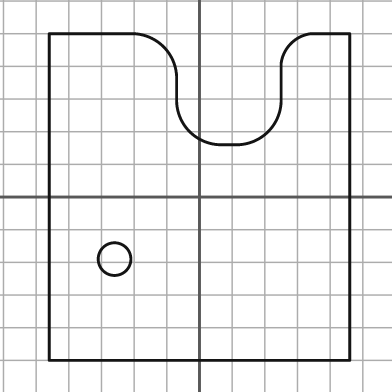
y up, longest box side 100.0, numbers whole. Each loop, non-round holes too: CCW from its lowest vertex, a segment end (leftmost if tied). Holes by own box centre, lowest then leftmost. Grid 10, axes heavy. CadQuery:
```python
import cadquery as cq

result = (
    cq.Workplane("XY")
    .moveTo(-46.0, -50.0)
    .lineTo(46.0, -50.0)
    .lineTo(46.0, 50.0)
    .lineTo(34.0, 50.0)
    .threePointArc((28.0, 47.0), (25.0, 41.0))
    .lineTo(25.0, 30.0)
    .threePointArc((21.0, 20.0), (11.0, 16.0))
    .lineTo(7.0, 16.0)
    .threePointArc((-3.0, 20.0), (-7.0, 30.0))
    .lineTo(-7.0, 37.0)
    .threePointArc((-11.0, 46.0), (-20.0, 50.0))
    .lineTo(-46.0, 50.0)
    .close()
    .moveTo(-26.0, -19.0)
    .circle(5.0)
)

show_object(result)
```